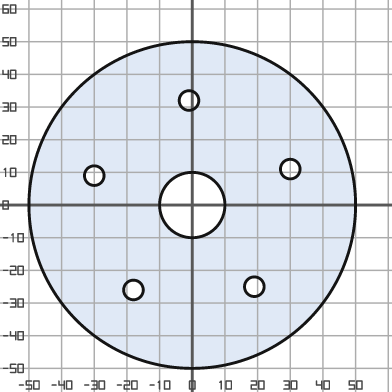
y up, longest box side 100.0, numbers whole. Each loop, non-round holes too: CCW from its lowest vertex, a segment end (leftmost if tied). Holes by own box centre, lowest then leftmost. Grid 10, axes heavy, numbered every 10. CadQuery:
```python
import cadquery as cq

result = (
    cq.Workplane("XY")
    .moveTo(0.0, 0.0)
    .circle(50.0)
    .moveTo(-18.0, -26.0)
    .circle(3.0)
    .moveTo(19.0, -25.0)
    .circle(3.0)
    .moveTo(0.0, 0.0)
    .circle(10.0)
    .moveTo(-30.0, 9.0)
    .circle(3.0)
    .moveTo(30.0, 11.0)
    .circle(3.0)
    .moveTo(-1.0, 32.0)
    .circle(3.0)
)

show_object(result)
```